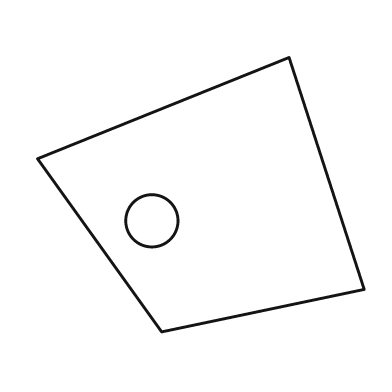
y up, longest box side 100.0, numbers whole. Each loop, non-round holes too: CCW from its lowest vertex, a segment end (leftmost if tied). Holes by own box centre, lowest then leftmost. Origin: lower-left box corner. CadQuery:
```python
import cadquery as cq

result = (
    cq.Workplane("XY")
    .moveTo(38.0, 0.0)
    .lineTo(100.0, 13.0)
    .lineTo(77.0, 84.0)
    .lineTo(0.0, 53.0)
    .close()
    .moveTo(35.0, 34.0)
    .circle(8.0)
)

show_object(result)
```